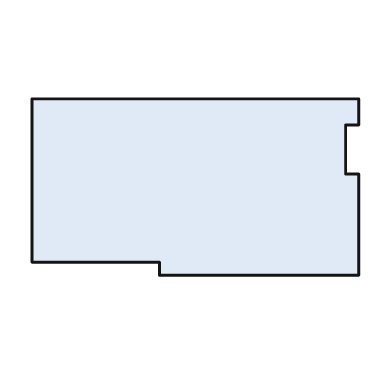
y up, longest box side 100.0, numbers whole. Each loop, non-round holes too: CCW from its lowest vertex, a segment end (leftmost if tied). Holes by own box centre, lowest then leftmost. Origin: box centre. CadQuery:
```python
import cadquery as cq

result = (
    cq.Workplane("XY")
    .moveTo(-11.0, -27.0)
    .lineTo(50.0, -27.0)
    .lineTo(50.0, 4.0)
    .lineTo(46.0, 4.0)
    .lineTo(46.0, 19.0)
    .lineTo(50.0, 19.0)
    .lineTo(50.0, 27.0)
    .lineTo(-50.0, 27.0)
    .lineTo(-50.0, -23.0)
    .lineTo(-11.0, -23.0)
    .close()
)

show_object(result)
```